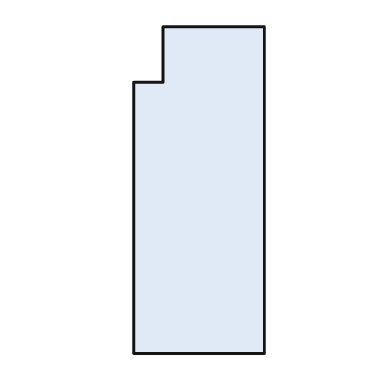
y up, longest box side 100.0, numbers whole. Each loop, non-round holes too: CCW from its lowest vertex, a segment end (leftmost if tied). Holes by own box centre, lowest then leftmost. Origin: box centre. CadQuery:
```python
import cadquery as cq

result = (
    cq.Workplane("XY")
    .moveTo(-20.0, -50.0)
    .lineTo(20.0, -50.0)
    .lineTo(20.0, 50.0)
    .lineTo(-11.0, 50.0)
    .lineTo(-11.0, 33.0)
    .lineTo(-20.0, 33.0)
    .close()
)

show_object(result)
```